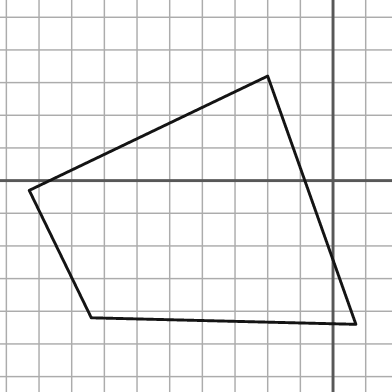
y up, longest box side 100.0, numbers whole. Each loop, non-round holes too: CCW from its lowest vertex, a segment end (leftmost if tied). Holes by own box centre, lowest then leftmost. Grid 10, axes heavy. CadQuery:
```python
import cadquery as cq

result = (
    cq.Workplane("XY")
    .moveTo(7.0, -44.0)
    .lineTo(-20.0, 32.0)
    .lineTo(-93.0, -3.0)
    .lineTo(-74.0, -42.0)
    .close()
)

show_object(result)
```